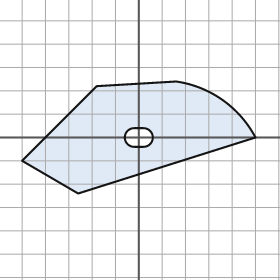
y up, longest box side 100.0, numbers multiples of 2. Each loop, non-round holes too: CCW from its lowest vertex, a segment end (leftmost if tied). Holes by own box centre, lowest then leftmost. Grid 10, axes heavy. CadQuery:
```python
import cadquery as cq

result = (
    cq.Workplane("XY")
    .moveTo(-26.0, -24.0)
    .lineTo(50.0, 0.0)
    .threePointArc((36.0, 16.0), (16.0, 24.0))
    .lineTo(-18.0, 22.0)
    .lineTo(-50.0, -10.0)
    .close()
    .moveTo(-2.0, -4.0)
    .lineTo(2.0, -4.0)
    .threePointArc((6.0, 0.0), (2.0, 4.0))
    .lineTo(-2.0, 4.0)
    .threePointArc((-6.0, 0.0), (-2.0, -4.0))
    .close()
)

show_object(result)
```